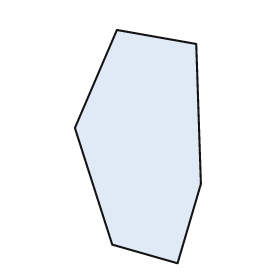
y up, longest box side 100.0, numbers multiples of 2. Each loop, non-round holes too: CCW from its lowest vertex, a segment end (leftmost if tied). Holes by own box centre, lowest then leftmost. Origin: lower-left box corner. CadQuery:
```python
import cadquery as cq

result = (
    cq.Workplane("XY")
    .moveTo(44.0, 0.0)
    .lineTo(54.0, 34.0)
    .lineTo(52.0, 94.0)
    .lineTo(18.0, 100.0)
    .lineTo(0.0, 58.0)
    .lineTo(16.0, 8.0)
    .close()
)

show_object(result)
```